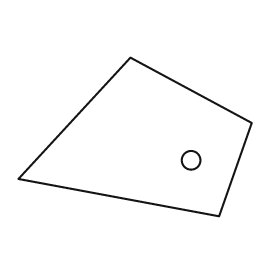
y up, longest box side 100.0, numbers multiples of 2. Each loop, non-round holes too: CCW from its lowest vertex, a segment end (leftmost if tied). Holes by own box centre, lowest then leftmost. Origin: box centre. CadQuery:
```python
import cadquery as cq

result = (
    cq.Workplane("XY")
    .moveTo(36.0, -34.0)
    .lineTo(50.0, 6.0)
    .lineTo(-2.0, 34.0)
    .lineTo(-50.0, -18.0)
    .close()
    .moveTo(24.0, -10.0)
    .circle(4.0)
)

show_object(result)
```